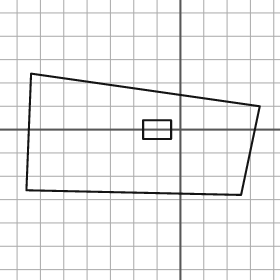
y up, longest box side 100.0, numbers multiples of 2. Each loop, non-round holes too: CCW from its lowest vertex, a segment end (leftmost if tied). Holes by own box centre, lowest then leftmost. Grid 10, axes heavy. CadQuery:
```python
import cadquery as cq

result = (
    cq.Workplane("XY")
    .moveTo(26.0, -28.0)
    .lineTo(34.0, 10.0)
    .lineTo(-64.0, 24.0)
    .lineTo(-66.0, -26.0)
    .close()
    .moveTo(-16.0, -4.0)
    .lineTo(-4.0, -4.0)
    .lineTo(-4.0, 4.0)
    .lineTo(-16.0, 4.0)
    .close()
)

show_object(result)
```